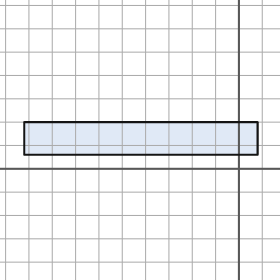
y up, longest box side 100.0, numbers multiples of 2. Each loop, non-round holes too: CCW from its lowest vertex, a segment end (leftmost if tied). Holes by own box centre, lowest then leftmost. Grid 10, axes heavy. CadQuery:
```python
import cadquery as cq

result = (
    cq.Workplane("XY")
    .moveTo(-92.0, 6.0)
    .lineTo(8.0, 6.0)
    .lineTo(8.0, 20.0)
    .lineTo(-92.0, 20.0)
    .close()
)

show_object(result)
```